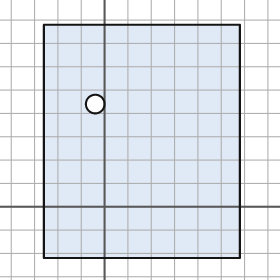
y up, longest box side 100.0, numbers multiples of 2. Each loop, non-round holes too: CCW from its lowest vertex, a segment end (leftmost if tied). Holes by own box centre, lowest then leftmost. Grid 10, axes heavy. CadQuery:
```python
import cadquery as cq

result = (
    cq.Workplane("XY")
    .moveTo(-26.0, -22.0)
    .lineTo(58.0, -22.0)
    .lineTo(58.0, 78.0)
    .lineTo(-26.0, 78.0)
    .close()
    .moveTo(-4.0, 44.0)
    .circle(4.0)
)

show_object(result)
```